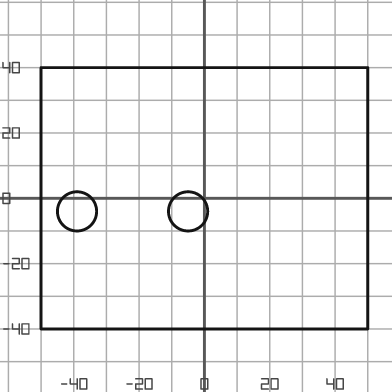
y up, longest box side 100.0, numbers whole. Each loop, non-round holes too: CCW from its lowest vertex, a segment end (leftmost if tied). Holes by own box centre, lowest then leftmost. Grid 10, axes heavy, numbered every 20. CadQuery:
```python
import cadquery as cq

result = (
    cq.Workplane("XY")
    .moveTo(-50.0, -40.0)
    .lineTo(50.0, -40.0)
    .lineTo(50.0, 40.0)
    .lineTo(-50.0, 40.0)
    .close()
    .moveTo(-39.0, -4.0)
    .circle(6.0)
    .moveTo(-5.0, -4.0)
    .circle(6.0)
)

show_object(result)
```